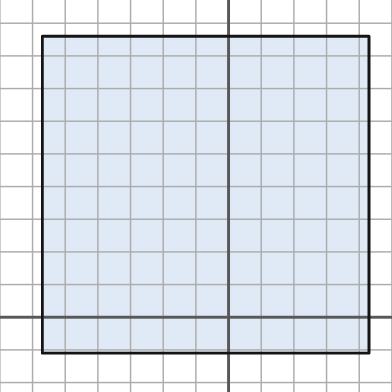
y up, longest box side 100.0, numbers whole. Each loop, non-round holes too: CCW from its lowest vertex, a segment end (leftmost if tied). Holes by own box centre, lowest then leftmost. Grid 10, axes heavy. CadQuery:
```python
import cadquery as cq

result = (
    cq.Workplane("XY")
    .moveTo(-57.0, -11.0)
    .lineTo(43.0, -11.0)
    .lineTo(43.0, 86.0)
    .lineTo(-57.0, 86.0)
    .close()
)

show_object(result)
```